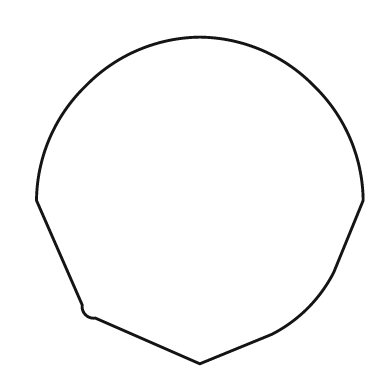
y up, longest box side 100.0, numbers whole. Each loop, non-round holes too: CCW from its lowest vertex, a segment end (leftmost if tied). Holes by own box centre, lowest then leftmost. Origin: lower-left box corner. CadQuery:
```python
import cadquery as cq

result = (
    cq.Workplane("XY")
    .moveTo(50.0, 0.0)
    .lineTo(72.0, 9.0)
    .threePointArc((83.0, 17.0), (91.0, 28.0))
    .lineTo(100.0, 50.0)
    .threePointArc((96.0, 69.0), (85.0, 85.0))
    .threePointArc((69.0, 96.0), (50.0, 100.0))
    .threePointArc((31.0, 96.0), (15.0, 85.0))
    .threePointArc((4.0, 69.0), (0.0, 50.0))
    .lineTo(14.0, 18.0)
    .threePointArc((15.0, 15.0), (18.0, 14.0))
    .close()
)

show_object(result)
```